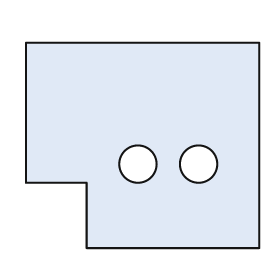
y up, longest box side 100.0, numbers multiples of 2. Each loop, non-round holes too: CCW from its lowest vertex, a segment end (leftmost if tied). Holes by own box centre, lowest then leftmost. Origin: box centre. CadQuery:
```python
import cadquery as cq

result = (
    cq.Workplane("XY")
    .moveTo(-24.0, -44.0)
    .lineTo(50.0, -44.0)
    .lineTo(50.0, 44.0)
    .lineTo(-50.0, 44.0)
    .lineTo(-50.0, -16.0)
    .lineTo(-24.0, -16.0)
    .close()
    .moveTo(-2.0, -8.0)
    .circle(8.0)
    .moveTo(24.0, -8.0)
    .circle(8.0)
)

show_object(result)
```